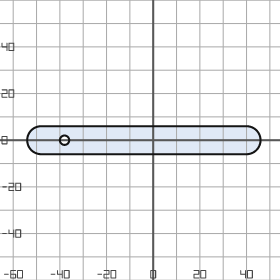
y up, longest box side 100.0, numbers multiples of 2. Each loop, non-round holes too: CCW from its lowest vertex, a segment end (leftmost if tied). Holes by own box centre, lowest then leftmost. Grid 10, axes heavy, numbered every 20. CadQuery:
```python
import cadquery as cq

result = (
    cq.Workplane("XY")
    .moveTo(-48.0, -6.0)
    .lineTo(40.0, -6.0)
    .threePointArc((46.0, 0.0), (40.0, 6.0))
    .lineTo(-48.0, 6.0)
    .threePointArc((-54.0, 0.0), (-48.0, -6.0))
    .close()
    .moveTo(-38.0, 0.0)
    .circle(2.0)
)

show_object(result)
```